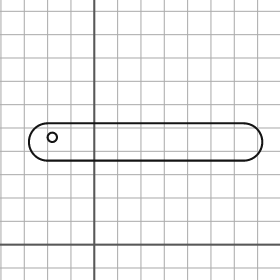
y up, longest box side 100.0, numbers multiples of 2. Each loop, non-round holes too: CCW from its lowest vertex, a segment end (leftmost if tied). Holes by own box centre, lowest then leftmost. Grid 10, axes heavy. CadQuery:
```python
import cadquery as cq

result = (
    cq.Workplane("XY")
    .moveTo(-20.0, 36.0)
    .lineTo(64.0, 36.0)
    .threePointArc((72.0, 44.0), (64.0, 52.0))
    .lineTo(-20.0, 52.0)
    .threePointArc((-28.0, 44.0), (-20.0, 36.0))
    .close()
    .moveTo(-18.0, 46.0)
    .circle(2.0)
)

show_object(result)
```